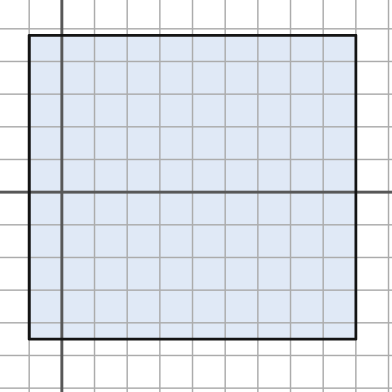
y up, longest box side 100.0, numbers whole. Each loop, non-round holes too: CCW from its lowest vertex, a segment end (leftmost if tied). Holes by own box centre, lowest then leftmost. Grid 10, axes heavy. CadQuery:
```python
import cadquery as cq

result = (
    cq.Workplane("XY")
    .moveTo(-10.0, -45.0)
    .lineTo(90.0, -45.0)
    .lineTo(90.0, 48.0)
    .lineTo(-10.0, 48.0)
    .close()
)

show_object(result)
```